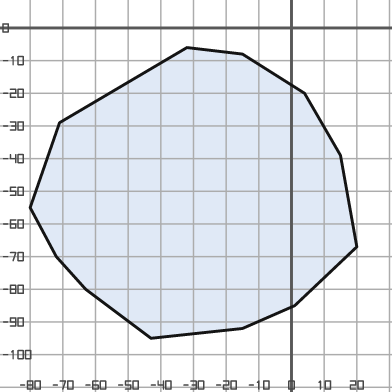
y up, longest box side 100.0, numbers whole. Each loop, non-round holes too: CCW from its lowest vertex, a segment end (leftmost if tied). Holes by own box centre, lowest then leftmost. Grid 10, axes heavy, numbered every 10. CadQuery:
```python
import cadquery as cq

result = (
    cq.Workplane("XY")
    .moveTo(-43.0, -95.0)
    .lineTo(-15.0, -92.0)
    .lineTo(1.0, -85.0)
    .lineTo(20.0, -67.0)
    .lineTo(15.0, -39.0)
    .lineTo(4.0, -20.0)
    .lineTo(-15.0, -8.0)
    .lineTo(-32.0, -6.0)
    .lineTo(-71.0, -29.0)
    .lineTo(-80.0, -55.0)
    .lineTo(-72.0, -70.0)
    .lineTo(-63.0, -80.0)
    .close()
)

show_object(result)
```